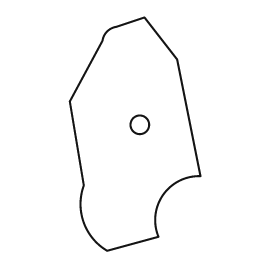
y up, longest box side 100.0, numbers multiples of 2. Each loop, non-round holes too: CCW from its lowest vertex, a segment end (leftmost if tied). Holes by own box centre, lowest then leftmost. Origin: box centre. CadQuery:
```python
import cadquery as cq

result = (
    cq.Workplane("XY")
    .moveTo(-12.0, -50.0)
    .lineTo(10.0, -44.0)
    .threePointArc((12.0, -26.0), (28.0, -18.0))
    .lineTo(18.0, 32.0)
    .lineTo(4.0, 50.0)
    .lineTo(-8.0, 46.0)
    .threePointArc((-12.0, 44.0), (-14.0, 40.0))
    .lineTo(-28.0, 14.0)
    .lineTo(-22.0, -22.0)
    .threePointArc((-22.0, -38.0), (-12.0, -50.0))
    .close()
    .moveTo(2.0, 4.0)
    .circle(4.0)
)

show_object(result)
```